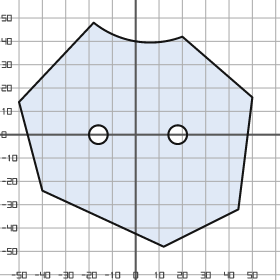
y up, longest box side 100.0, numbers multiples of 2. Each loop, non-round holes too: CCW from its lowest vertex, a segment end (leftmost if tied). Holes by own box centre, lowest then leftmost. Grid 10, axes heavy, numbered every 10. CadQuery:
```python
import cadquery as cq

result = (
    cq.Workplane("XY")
    .moveTo(12.0, -48.0)
    .lineTo(44.0, -32.0)
    .lineTo(50.0, 16.0)
    .lineTo(20.0, 42.0)
    .threePointArc((0.0, 40.0), (-18.0, 48.0))
    .lineTo(-50.0, 14.0)
    .lineTo(-40.0, -24.0)
    .close()
    .moveTo(-16.0, 0.0)
    .circle(4.0)
    .moveTo(18.0, 0.0)
    .circle(4.0)
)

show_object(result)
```